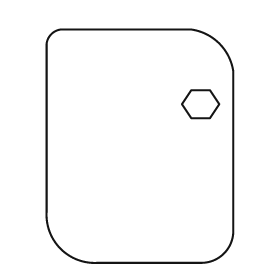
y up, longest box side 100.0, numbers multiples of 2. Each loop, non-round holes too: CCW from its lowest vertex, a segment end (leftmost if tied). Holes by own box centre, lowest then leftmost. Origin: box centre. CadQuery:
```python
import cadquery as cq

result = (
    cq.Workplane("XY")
    .moveTo(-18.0, -50.0)
    .lineTo(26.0, -50.0)
    .threePointArc((36.0, -46.0), (40.0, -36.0))
    .lineTo(40.0, 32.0)
    .threePointArc((34.0, 44.0), (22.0, 50.0))
    .lineTo(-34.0, 50.0)
    .threePointArc((-38.0, 48.0), (-40.0, 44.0))
    .lineTo(-40.0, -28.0)
    .threePointArc((-34.0, -44.0), (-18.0, -50.0))
    .close()
    .moveTo(22.0, 12.0)
    .lineTo(30.0, 12.0)
    .lineTo(34.0, 18.0)
    .lineTo(30.0, 24.0)
    .lineTo(22.0, 24.0)
    .lineTo(18.0, 18.0)
    .close()
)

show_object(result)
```